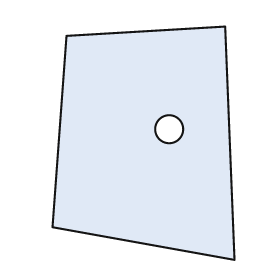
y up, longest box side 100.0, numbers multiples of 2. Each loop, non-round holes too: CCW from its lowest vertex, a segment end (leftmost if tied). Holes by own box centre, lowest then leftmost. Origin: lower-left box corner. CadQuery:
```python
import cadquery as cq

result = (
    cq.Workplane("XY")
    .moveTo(78.0, 0.0)
    .lineTo(74.0, 100.0)
    .lineTo(6.0, 96.0)
    .lineTo(0.0, 14.0)
    .close()
    .moveTo(50.0, 56.0)
    .circle(6.0)
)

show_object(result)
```